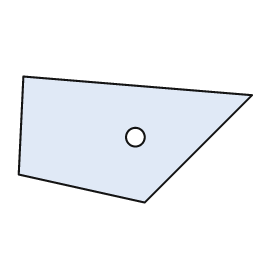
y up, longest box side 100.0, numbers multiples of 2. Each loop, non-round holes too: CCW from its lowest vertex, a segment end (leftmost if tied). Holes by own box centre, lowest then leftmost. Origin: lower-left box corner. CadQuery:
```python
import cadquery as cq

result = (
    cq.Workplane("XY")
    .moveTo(54.0, 0.0)
    .lineTo(100.0, 46.0)
    .lineTo(2.0, 54.0)
    .lineTo(0.0, 12.0)
    .close()
    .moveTo(50.0, 28.0)
    .circle(4.0)
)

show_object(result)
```